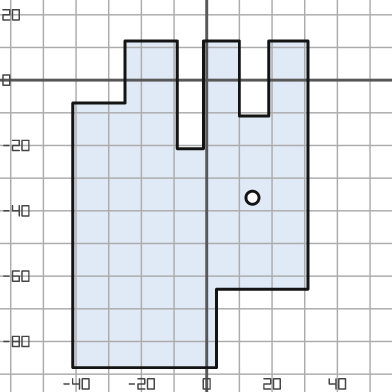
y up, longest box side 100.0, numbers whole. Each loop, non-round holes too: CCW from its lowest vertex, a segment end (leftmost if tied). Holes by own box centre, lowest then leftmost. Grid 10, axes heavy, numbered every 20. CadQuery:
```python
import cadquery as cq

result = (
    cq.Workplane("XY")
    .moveTo(-41.0, -88.0)
    .lineTo(3.0, -88.0)
    .lineTo(3.0, -64.0)
    .lineTo(31.0, -64.0)
    .lineTo(31.0, 12.0)
    .lineTo(19.0, 12.0)
    .lineTo(19.0, -11.0)
    .lineTo(10.0, -11.0)
    .lineTo(10.0, 12.0)
    .lineTo(-1.0, 12.0)
    .lineTo(-1.0, -21.0)
    .lineTo(-9.0, -21.0)
    .lineTo(-9.0, 12.0)
    .lineTo(-25.0, 12.0)
    .lineTo(-25.0, -7.0)
    .lineTo(-41.0, -7.0)
    .close()
    .moveTo(14.0, -36.0)
    .circle(2.0)
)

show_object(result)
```